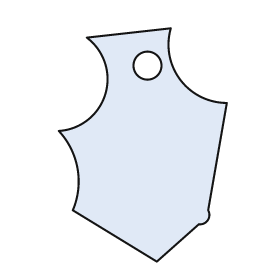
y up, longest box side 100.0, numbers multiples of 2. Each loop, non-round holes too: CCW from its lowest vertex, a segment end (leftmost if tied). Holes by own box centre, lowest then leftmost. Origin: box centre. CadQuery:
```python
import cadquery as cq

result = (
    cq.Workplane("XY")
    .moveTo(6.0, -50.0)
    .lineTo(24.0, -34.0)
    .threePointArc((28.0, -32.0), (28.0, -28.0))
    .lineTo(36.0, 18.0)
    .threePointArc((16.0, 28.0), (12.0, 50.0))
    .lineTo(-24.0, 46.0)
    .threePointArc((-16.0, 22.0), (-36.0, 6.0))
    .threePointArc((-28.0, -10.0), (-30.0, -28.0))
    .close()
    .moveTo(2.0, 34.0)
    .circle(6.0)
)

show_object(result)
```